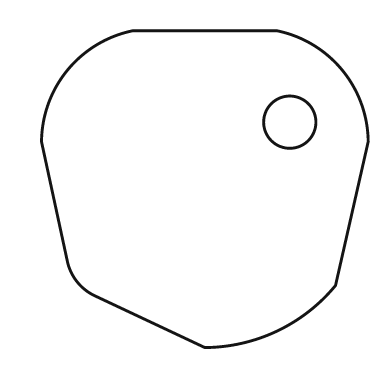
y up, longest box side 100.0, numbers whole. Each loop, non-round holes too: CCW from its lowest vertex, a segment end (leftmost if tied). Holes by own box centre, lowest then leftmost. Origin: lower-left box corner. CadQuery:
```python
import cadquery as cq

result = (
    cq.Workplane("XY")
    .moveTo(50.0, 0.0)
    .threePointArc((72.0, 5.0), (90.0, 19.0))
    .lineTo(100.0, 63.0)
    .threePointArc((92.0, 85.0), (72.0, 97.0))
    .lineTo(28.0, 97.0)
    .threePointArc((8.0, 85.0), (0.0, 63.0))
    .lineTo(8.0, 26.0)
    .threePointArc((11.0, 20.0), (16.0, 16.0))
    .close()
    .moveTo(76.0, 69.0)
    .circle(8.0)
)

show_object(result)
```